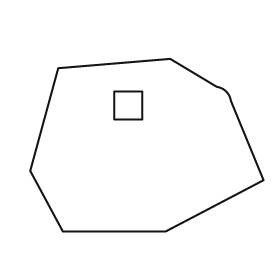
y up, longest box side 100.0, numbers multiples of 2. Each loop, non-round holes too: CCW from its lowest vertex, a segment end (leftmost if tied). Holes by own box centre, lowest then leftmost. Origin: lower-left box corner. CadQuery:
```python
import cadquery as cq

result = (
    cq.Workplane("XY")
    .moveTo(14.0, 0.0)
    .lineTo(58.0, 0.0)
    .lineTo(100.0, 22.0)
    .lineTo(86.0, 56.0)
    .threePointArc((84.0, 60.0), (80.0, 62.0))
    .lineTo(60.0, 74.0)
    .lineTo(12.0, 70.0)
    .lineTo(0.0, 26.0)
    .close()
    .moveTo(36.0, 48.0)
    .lineTo(48.0, 48.0)
    .lineTo(48.0, 60.0)
    .lineTo(36.0, 60.0)
    .close()
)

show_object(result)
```